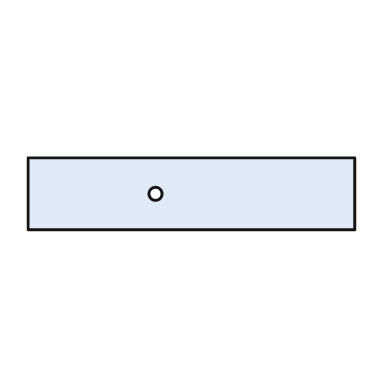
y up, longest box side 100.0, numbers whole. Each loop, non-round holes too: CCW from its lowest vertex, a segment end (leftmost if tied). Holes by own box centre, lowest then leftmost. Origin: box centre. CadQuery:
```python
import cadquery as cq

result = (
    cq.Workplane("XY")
    .moveTo(-50.0, -11.0)
    .lineTo(50.0, -11.0)
    .lineTo(50.0, 11.0)
    .lineTo(-50.0, 11.0)
    .close()
    .moveTo(-11.0, 0.0)
    .circle(2.0)
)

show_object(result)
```